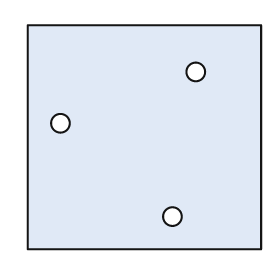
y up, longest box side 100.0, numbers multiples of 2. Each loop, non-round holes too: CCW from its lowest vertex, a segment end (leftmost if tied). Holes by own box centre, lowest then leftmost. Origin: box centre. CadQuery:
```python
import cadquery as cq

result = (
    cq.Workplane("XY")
    .moveTo(-50.0, -48.0)
    .lineTo(50.0, -48.0)
    .lineTo(50.0, 48.0)
    .lineTo(-50.0, 48.0)
    .close()
    .moveTo(12.0, -34.0)
    .circle(4.0)
    .moveTo(-36.0, 6.0)
    .circle(4.0)
    .moveTo(22.0, 28.0)
    .circle(4.0)
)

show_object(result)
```